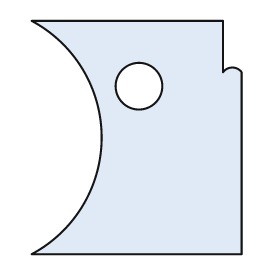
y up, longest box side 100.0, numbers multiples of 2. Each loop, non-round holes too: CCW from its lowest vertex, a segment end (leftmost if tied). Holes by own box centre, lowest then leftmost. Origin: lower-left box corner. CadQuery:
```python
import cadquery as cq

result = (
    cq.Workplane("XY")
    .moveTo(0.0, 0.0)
    .lineTo(90.0, 0.0)
    .lineTo(90.0, 78.0)
    .threePointArc((86.0, 80.0), (82.0, 78.0))
    .lineTo(82.0, 100.0)
    .lineTo(0.0, 100.0)
    .threePointArc((30.0, 50.0), (0.0, 0.0))
    .close()
    .moveTo(46.0, 72.0)
    .circle(10.0)
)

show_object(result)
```